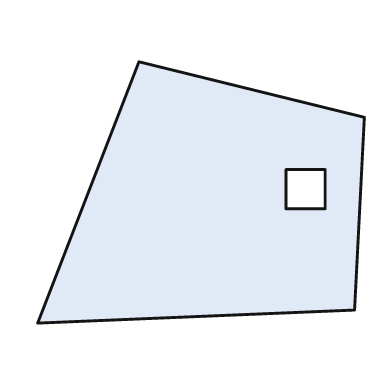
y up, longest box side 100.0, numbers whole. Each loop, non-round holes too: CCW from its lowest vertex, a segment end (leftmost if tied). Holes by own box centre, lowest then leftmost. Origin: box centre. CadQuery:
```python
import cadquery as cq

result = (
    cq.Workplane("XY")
    .moveTo(-50.0, -40.0)
    .lineTo(47.0, -36.0)
    .lineTo(50.0, 23.0)
    .lineTo(-19.0, 40.0)
    .close()
    .moveTo(26.0, -5.0)
    .lineTo(38.0, -5.0)
    .lineTo(38.0, 7.0)
    .lineTo(26.0, 7.0)
    .close()
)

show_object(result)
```